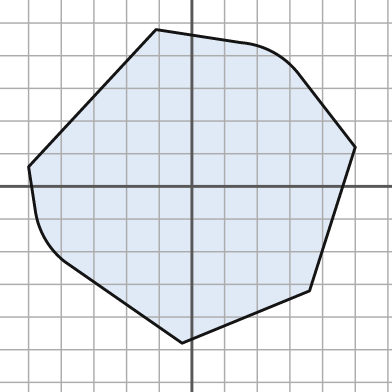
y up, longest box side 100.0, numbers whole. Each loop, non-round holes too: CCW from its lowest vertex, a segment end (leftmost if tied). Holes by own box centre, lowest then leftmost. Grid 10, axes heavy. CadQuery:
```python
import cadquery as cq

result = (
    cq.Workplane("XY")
    .moveTo(-3.0, -48.0)
    .lineTo(36.0, -32.0)
    .lineTo(50.0, 12.0)
    .lineTo(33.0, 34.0)
    .threePointArc((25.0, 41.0), (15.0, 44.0))
    .lineTo(-11.0, 48.0)
    .lineTo(-50.0, 6.0)
    .lineTo(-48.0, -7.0)
    .threePointArc((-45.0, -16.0), (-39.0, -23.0))
    .close()
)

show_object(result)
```